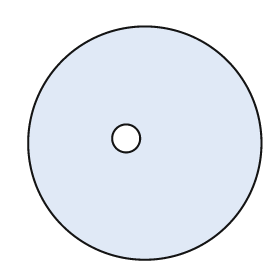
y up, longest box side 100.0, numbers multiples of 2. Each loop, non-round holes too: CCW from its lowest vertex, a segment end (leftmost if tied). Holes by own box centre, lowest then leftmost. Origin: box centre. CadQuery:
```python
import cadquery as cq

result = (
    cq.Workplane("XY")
    .moveTo(0.0, 0.0)
    .circle(50.0)
    .moveTo(-8.0, 2.0)
    .circle(6.0)
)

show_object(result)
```